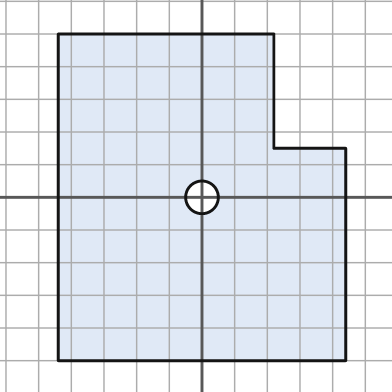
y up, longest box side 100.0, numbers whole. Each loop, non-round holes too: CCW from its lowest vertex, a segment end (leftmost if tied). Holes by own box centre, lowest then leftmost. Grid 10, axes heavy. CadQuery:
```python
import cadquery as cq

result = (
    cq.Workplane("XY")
    .moveTo(-44.0, -50.0)
    .lineTo(44.0, -50.0)
    .lineTo(44.0, 15.0)
    .lineTo(22.0, 15.0)
    .lineTo(22.0, 50.0)
    .lineTo(-44.0, 50.0)
    .close()
    .moveTo(0.0, 0.0)
    .circle(5.0)
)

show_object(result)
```